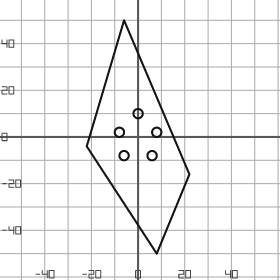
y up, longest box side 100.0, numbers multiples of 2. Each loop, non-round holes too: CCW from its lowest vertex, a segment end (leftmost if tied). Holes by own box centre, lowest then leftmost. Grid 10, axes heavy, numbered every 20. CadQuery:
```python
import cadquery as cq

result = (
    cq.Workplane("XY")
    .moveTo(8.0, -50.0)
    .lineTo(22.0, -16.0)
    .lineTo(-6.0, 50.0)
    .lineTo(-22.0, -4.0)
    .close()
    .moveTo(-6.0, -8.0)
    .circle(2.0)
    .moveTo(6.0, -8.0)
    .circle(2.0)
    .moveTo(-8.0, 2.0)
    .circle(2.0)
    .moveTo(8.0, 2.0)
    .circle(2.0)
    .moveTo(0.0, 10.0)
    .circle(2.0)
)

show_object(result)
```